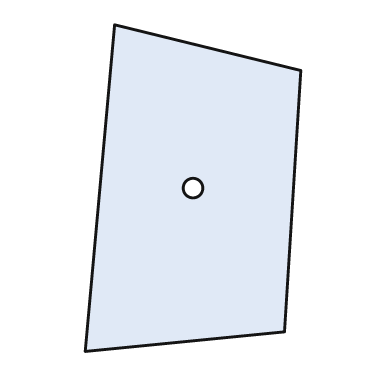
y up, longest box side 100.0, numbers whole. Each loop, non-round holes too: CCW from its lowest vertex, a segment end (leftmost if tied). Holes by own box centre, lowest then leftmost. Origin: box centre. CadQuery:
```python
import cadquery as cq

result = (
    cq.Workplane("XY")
    .moveTo(-33.0, -50.0)
    .lineTo(28.0, -44.0)
    .lineTo(33.0, 36.0)
    .lineTo(-24.0, 50.0)
    .close()
    .moveTo(0.0, 0.0)
    .circle(3.0)
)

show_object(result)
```